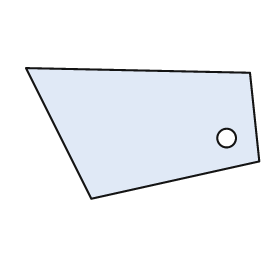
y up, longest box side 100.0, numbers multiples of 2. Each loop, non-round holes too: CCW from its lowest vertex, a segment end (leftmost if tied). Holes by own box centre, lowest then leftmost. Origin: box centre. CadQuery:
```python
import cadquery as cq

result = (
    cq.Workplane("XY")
    .moveTo(-22.0, -28.0)
    .lineTo(50.0, -12.0)
    .lineTo(46.0, 26.0)
    .lineTo(-50.0, 28.0)
    .close()
    .moveTo(36.0, -2.0)
    .circle(4.0)
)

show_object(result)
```